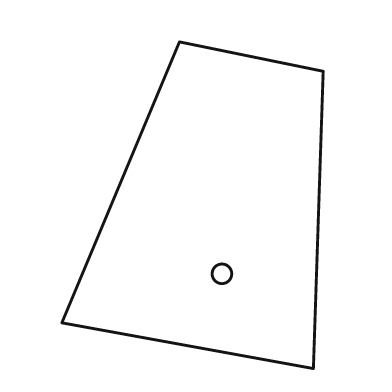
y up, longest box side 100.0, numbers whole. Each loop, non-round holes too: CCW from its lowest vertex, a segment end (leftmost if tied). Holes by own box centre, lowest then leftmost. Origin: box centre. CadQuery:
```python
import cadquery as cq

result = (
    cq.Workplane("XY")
    .moveTo(37.0, -50.0)
    .lineTo(40.0, 41.0)
    .lineTo(-4.0, 50.0)
    .lineTo(-40.0, -36.0)
    .close()
    .moveTo(9.0, -21.0)
    .circle(3.0)
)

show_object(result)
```